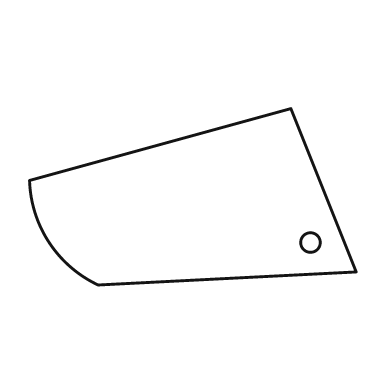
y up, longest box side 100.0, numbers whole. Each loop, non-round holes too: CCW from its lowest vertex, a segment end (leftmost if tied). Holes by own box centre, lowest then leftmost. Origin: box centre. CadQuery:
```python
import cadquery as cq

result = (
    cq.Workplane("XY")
    .moveTo(-29.0, -27.0)
    .lineTo(50.0, -23.0)
    .lineTo(30.0, 27.0)
    .lineTo(-50.0, 5.0)
    .threePointArc((-44.0, -14.0), (-29.0, -27.0))
    .close()
    .moveTo(36.0, -14.0)
    .circle(3.0)
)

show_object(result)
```